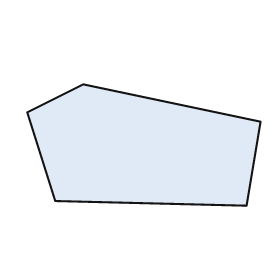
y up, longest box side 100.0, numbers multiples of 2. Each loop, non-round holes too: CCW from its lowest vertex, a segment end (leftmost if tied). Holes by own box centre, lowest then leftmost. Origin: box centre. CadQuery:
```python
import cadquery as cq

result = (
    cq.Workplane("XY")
    .moveTo(44.0, -26.0)
    .lineTo(50.0, 10.0)
    .lineTo(-26.0, 26.0)
    .lineTo(-50.0, 14.0)
    .lineTo(-38.0, -24.0)
    .close()
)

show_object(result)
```